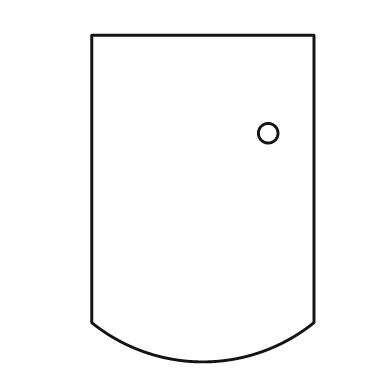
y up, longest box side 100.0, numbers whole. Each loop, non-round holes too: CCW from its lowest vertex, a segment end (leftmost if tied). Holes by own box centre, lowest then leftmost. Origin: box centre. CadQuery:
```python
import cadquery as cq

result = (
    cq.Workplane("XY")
    .moveTo(-34.0, -38.0)
    .threePointArc((0.0, -50.0), (34.0, -38.0))
    .lineTo(34.0, 50.0)
    .lineTo(-34.0, 50.0)
    .close()
    .moveTo(20.0, 20.0)
    .circle(3.0)
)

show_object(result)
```